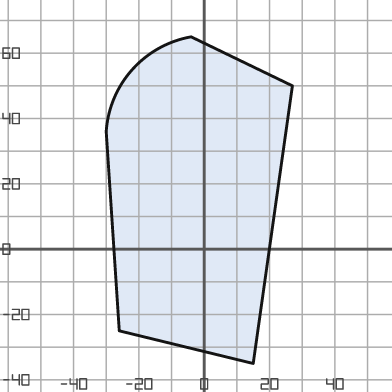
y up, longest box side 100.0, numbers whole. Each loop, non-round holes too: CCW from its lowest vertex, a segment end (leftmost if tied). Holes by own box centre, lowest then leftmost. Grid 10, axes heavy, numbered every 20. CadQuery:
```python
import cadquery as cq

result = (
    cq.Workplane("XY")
    .moveTo(15.0, -35.0)
    .lineTo(27.0, 50.0)
    .lineTo(-4.0, 65.0)
    .threePointArc((-22.0, 55.0), (-30.0, 36.0))
    .lineTo(-26.0, -25.0)
    .close()
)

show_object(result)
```